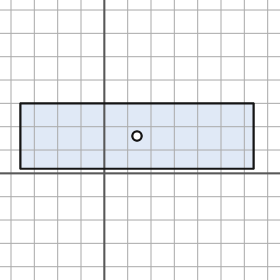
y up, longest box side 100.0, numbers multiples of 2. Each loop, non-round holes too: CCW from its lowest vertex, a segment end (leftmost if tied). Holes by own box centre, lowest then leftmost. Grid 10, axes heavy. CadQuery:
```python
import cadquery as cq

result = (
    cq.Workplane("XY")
    .moveTo(-36.0, 2.0)
    .lineTo(64.0, 2.0)
    .lineTo(64.0, 30.0)
    .lineTo(-36.0, 30.0)
    .close()
    .moveTo(14.0, 16.0)
    .circle(2.0)
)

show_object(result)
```